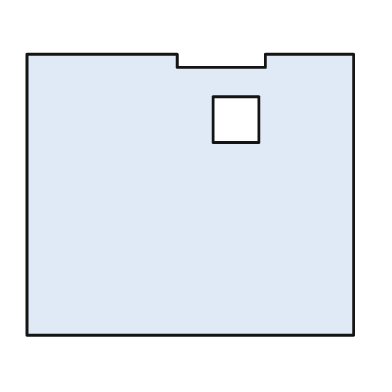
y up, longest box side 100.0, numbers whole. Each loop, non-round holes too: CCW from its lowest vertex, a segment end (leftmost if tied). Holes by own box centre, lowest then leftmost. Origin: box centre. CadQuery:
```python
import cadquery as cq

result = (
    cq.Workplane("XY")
    .moveTo(-50.0, -43.0)
    .lineTo(50.0, -43.0)
    .lineTo(50.0, 43.0)
    .lineTo(23.0, 43.0)
    .lineTo(23.0, 39.0)
    .lineTo(-4.0, 39.0)
    .lineTo(-4.0, 43.0)
    .lineTo(-50.0, 43.0)
    .close()
    .moveTo(7.0, 16.0)
    .lineTo(21.0, 16.0)
    .lineTo(21.0, 30.0)
    .lineTo(7.0, 30.0)
    .close()
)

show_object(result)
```